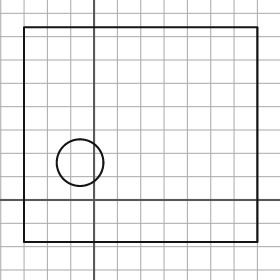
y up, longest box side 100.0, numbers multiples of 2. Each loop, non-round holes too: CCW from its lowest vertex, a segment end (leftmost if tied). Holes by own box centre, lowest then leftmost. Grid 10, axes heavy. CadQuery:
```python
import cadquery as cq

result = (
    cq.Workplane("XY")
    .moveTo(-30.0, -18.0)
    .lineTo(70.0, -18.0)
    .lineTo(70.0, 74.0)
    .lineTo(-30.0, 74.0)
    .close()
    .moveTo(-6.0, 16.0)
    .circle(10.0)
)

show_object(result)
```